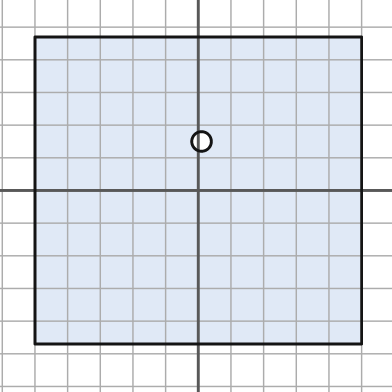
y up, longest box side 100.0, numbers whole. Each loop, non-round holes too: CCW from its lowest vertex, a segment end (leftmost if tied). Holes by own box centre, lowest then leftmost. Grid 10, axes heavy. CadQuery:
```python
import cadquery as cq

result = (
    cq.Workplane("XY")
    .moveTo(-50.0, -47.0)
    .lineTo(50.0, -47.0)
    .lineTo(50.0, 47.0)
    .lineTo(-50.0, 47.0)
    .close()
    .moveTo(1.0, 15.0)
    .circle(3.0)
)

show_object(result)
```